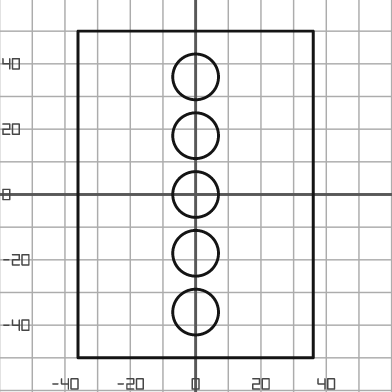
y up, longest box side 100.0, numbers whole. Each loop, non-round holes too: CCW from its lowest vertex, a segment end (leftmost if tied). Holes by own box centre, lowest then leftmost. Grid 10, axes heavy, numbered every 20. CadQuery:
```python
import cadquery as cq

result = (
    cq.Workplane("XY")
    .moveTo(-36.0, -50.0)
    .lineTo(36.0, -50.0)
    .lineTo(36.0, 50.0)
    .lineTo(-36.0, 50.0)
    .close()
    .moveTo(0.0, -36.0)
    .circle(7.0)
    .moveTo(0.0, -18.0)
    .circle(7.0)
    .moveTo(0.0, 0.0)
    .circle(7.0)
    .moveTo(0.0, 18.0)
    .circle(7.0)
    .moveTo(0.0, 36.0)
    .circle(7.0)
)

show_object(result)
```